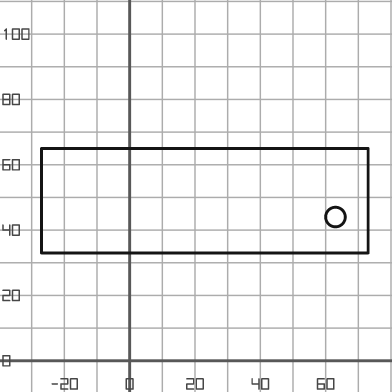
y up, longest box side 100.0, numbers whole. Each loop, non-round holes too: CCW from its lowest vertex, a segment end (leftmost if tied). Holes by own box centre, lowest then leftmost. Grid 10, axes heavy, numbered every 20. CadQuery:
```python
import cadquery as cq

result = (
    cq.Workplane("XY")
    .moveTo(-27.0, 33.0)
    .lineTo(73.0, 33.0)
    .lineTo(73.0, 65.0)
    .lineTo(-27.0, 65.0)
    .close()
    .moveTo(63.0, 44.0)
    .circle(3.0)
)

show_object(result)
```